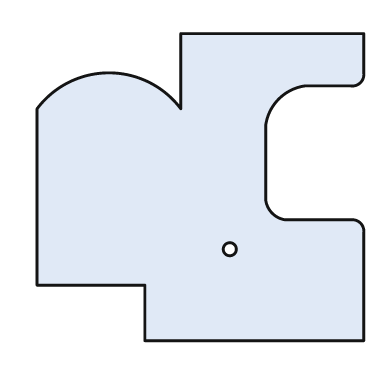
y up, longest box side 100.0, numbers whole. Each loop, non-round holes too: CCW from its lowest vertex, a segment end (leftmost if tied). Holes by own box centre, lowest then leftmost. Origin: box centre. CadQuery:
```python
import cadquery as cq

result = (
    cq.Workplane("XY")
    .moveTo(-17.0, -47.0)
    .lineTo(50.0, -47.0)
    .lineTo(50.0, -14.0)
    .threePointArc((49.0, -11.0), (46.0, -10.0))
    .lineTo(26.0, -10.0)
    .threePointArc((22.0, -8.0), (20.0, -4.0))
    .lineTo(20.0, 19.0)
    .threePointArc((24.0, 27.0), (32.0, 31.0))
    .lineTo(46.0, 31.0)
    .threePointArc((49.0, 32.0), (50.0, 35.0))
    .lineTo(50.0, 47.0)
    .lineTo(-6.0, 47.0)
    .lineTo(-6.0, 24.0)
    .threePointArc((-28.0, 35.0), (-50.0, 24.0))
    .lineTo(-50.0, -30.0)
    .lineTo(-17.0, -30.0)
    .close()
    .moveTo(9.0, -19.0)
    .circle(2.0)
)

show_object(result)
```